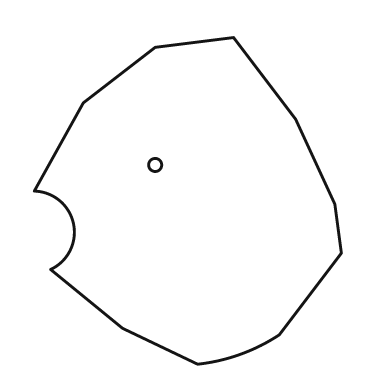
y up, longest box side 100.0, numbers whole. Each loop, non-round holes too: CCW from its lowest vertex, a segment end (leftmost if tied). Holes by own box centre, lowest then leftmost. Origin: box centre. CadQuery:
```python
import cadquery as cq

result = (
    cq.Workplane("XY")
    .moveTo(3.0, -50.0)
    .threePointArc((16.0, -47.0), (28.0, -41.0))
    .lineTo(47.0, -16.0)
    .lineTo(45.0, -1.0)
    .lineTo(33.0, 25.0)
    .lineTo(14.0, 50.0)
    .lineTo(-10.0, 47.0)
    .lineTo(-32.0, 30.0)
    .lineTo(-47.0, 3.0)
    .threePointArc((-35.0, -7.0), (-42.0, -21.0))
    .lineTo(-20.0, -39.0)
    .close()
    .moveTo(-10.0, 11.0)
    .circle(2.0)
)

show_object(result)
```